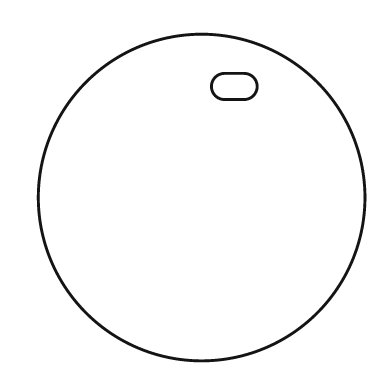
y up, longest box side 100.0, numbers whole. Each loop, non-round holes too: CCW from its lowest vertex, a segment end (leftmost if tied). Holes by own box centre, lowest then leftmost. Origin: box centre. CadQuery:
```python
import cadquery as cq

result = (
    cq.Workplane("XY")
    .moveTo(0.0, 0.0)
    .circle(50.0)
    .moveTo(7.0, 30.0)
    .lineTo(13.0, 30.0)
    .threePointArc((17.0, 34.0), (13.0, 38.0))
    .lineTo(7.0, 38.0)
    .threePointArc((3.0, 34.0), (7.0, 30.0))
    .close()
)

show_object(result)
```